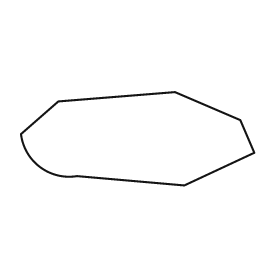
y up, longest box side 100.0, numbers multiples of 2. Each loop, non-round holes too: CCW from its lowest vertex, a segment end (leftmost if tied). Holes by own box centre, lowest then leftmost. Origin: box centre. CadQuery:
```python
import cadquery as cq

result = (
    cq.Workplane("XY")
    .moveTo(20.0, -20.0)
    .lineTo(50.0, -6.0)
    .lineTo(44.0, 8.0)
    .lineTo(16.0, 20.0)
    .lineTo(-34.0, 16.0)
    .lineTo(-50.0, 2.0)
    .threePointArc((-42.0, -12.0), (-26.0, -16.0))
    .close()
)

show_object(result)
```